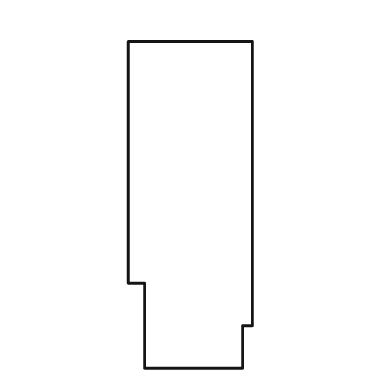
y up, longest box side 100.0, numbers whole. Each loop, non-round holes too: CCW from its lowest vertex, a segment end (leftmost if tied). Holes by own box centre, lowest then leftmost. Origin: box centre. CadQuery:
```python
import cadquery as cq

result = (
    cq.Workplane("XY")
    .moveTo(-14.0, -50.0)
    .lineTo(16.0, -50.0)
    .lineTo(16.0, -37.0)
    .lineTo(19.0, -37.0)
    .lineTo(19.0, 50.0)
    .lineTo(-19.0, 50.0)
    .lineTo(-19.0, -24.0)
    .lineTo(-14.0, -24.0)
    .close()
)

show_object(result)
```